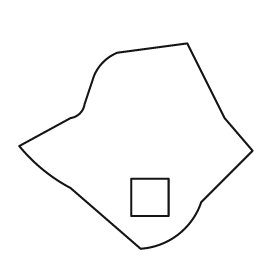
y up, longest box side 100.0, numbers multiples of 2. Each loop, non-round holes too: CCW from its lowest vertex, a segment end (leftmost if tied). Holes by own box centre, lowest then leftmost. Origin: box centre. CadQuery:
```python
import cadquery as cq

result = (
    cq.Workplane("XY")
    .moveTo(2.0, -44.0)
    .threePointArc((18.0, -38.0), (28.0, -24.0))
    .lineTo(50.0, -2.0)
    .lineTo(38.0, 12.0)
    .lineTo(22.0, 44.0)
    .lineTo(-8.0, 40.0)
    .threePointArc((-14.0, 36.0), (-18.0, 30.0))
    .lineTo(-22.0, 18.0)
    .threePointArc((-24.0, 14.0), (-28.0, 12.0))
    .lineTo(-50.0, 0.0)
    .threePointArc((-40.0, -10.0), (-28.0, -18.0))
    .close()
    .moveTo(-2.0, -30.0)
    .lineTo(14.0, -30.0)
    .lineTo(14.0, -14.0)
    .lineTo(-2.0, -14.0)
    .close()
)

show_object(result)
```